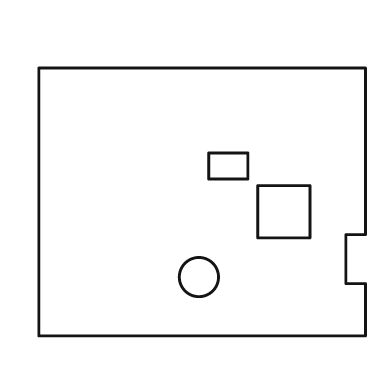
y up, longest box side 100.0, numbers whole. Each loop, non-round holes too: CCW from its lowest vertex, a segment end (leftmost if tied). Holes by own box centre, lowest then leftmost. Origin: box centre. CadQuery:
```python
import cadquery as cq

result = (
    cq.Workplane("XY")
    .moveTo(-50.0, -41.0)
    .lineTo(50.0, -41.0)
    .lineTo(50.0, -25.0)
    .lineTo(44.0, -25.0)
    .lineTo(44.0, -10.0)
    .lineTo(50.0, -10.0)
    .lineTo(50.0, 41.0)
    .lineTo(-50.0, 41.0)
    .close()
    .moveTo(-1.0, -23.0)
    .circle(6.0)
    .moveTo(17.0, -11.0)
    .lineTo(33.0, -11.0)
    .lineTo(33.0, 5.0)
    .lineTo(17.0, 5.0)
    .close()
    .moveTo(2.0, 7.0)
    .lineTo(14.0, 7.0)
    .lineTo(14.0, 15.0)
    .lineTo(2.0, 15.0)
    .close()
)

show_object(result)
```